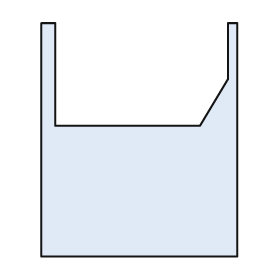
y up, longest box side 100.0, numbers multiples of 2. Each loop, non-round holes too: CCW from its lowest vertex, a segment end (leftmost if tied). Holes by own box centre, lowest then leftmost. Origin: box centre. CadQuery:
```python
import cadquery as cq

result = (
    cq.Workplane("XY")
    .moveTo(-42.0, -50.0)
    .lineTo(42.0, -50.0)
    .lineTo(42.0, 50.0)
    .lineTo(38.0, 50.0)
    .lineTo(38.0, 26.0)
    .lineTo(26.0, 6.0)
    .lineTo(-36.0, 6.0)
    .lineTo(-36.0, 50.0)
    .lineTo(-42.0, 50.0)
    .close()
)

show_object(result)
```